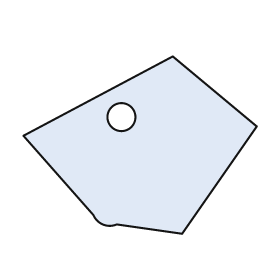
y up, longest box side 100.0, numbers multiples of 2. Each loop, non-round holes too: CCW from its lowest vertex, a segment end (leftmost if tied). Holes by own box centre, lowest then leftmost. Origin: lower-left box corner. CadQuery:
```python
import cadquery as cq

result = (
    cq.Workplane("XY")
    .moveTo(68.0, 0.0)
    .lineTo(100.0, 46.0)
    .lineTo(64.0, 76.0)
    .lineTo(0.0, 42.0)
    .lineTo(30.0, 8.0)
    .threePointArc((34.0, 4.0), (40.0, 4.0))
    .close()
    .moveTo(42.0, 50.0)
    .circle(6.0)
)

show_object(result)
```